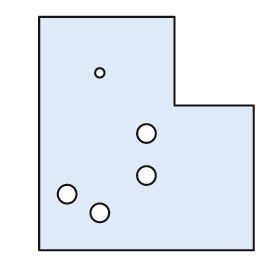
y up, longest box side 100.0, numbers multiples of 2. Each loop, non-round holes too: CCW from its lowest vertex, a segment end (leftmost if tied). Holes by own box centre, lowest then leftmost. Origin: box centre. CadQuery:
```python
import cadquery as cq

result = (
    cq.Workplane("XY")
    .moveTo(-46.0, -50.0)
    .lineTo(46.0, -50.0)
    .lineTo(46.0, 12.0)
    .lineTo(12.0, 12.0)
    .lineTo(12.0, 50.0)
    .lineTo(-46.0, 50.0)
    .close()
    .moveTo(-20.0, -34.0)
    .circle(4.0)
    .moveTo(-34.0, -26.0)
    .circle(4.0)
    .moveTo(0.0, -18.0)
    .circle(4.0)
    .moveTo(0.0, 0.0)
    .circle(4.0)
    .moveTo(-20.0, 26.0)
    .circle(2.0)
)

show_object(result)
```